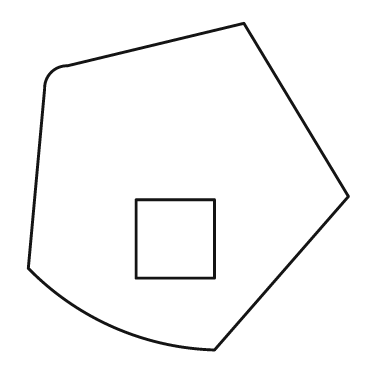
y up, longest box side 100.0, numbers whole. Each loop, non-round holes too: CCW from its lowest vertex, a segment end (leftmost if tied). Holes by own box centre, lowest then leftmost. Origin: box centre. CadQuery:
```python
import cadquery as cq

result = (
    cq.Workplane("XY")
    .moveTo(8.0, -50.0)
    .lineTo(49.0, -3.0)
    .lineTo(17.0, 50.0)
    .lineTo(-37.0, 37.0)
    .threePointArc((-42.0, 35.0), (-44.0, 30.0))
    .lineTo(-49.0, -25.0)
    .threePointArc((-23.0, -43.0), (8.0, -50.0))
    .close()
    .moveTo(-16.0, -28.0)
    .lineTo(8.0, -28.0)
    .lineTo(8.0, -4.0)
    .lineTo(-16.0, -4.0)
    .close()
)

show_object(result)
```